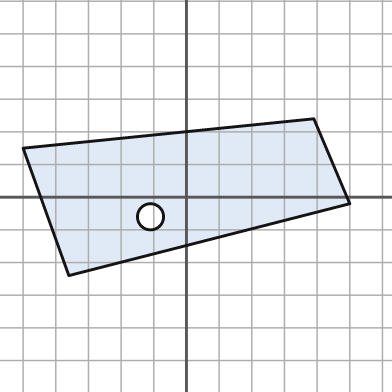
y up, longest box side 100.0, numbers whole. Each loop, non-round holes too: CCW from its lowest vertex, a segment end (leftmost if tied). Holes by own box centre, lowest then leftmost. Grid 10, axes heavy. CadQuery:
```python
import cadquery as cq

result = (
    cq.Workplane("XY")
    .moveTo(-36.0, -24.0)
    .lineTo(50.0, -2.0)
    .lineTo(39.0, 24.0)
    .lineTo(-50.0, 15.0)
    .close()
    .moveTo(-11.0, -6.0)
    .circle(4.0)
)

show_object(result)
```